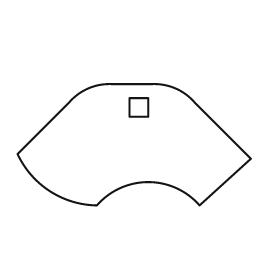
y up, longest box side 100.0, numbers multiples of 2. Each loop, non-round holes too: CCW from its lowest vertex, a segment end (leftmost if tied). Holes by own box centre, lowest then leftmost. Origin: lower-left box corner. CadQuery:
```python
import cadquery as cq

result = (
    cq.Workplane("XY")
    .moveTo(34.0, 0.0)
    .threePointArc((56.0, 10.0), (78.0, 0.0))
    .lineTo(100.0, 20.0)
    .lineTo(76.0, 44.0)
    .threePointArc((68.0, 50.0), (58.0, 52.0))
    .lineTo(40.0, 52.0)
    .threePointArc((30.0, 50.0), (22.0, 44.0))
    .lineTo(0.0, 22.0)
    .threePointArc((14.0, 6.0), (34.0, 0.0))
    .close()
    .moveTo(48.0, 38.0)
    .lineTo(56.0, 38.0)
    .lineTo(56.0, 46.0)
    .lineTo(48.0, 46.0)
    .close()
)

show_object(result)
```